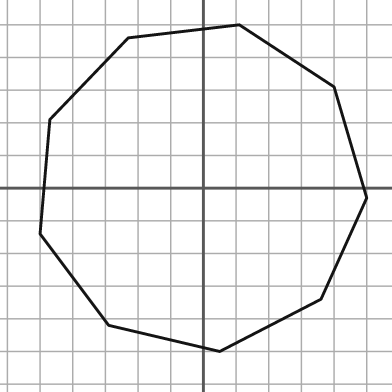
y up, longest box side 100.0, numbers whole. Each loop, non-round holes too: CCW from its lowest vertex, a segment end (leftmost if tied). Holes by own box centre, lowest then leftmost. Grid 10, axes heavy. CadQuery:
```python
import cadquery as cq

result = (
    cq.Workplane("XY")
    .moveTo(5.0, -50.0)
    .lineTo(36.0, -34.0)
    .lineTo(50.0, -3.0)
    .lineTo(40.0, 31.0)
    .lineTo(11.0, 50.0)
    .lineTo(-23.0, 46.0)
    .lineTo(-47.0, 21.0)
    .lineTo(-50.0, -14.0)
    .lineTo(-29.0, -42.0)
    .close()
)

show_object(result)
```